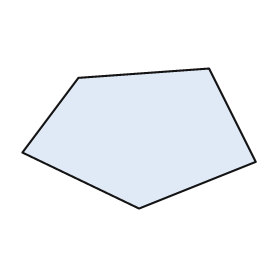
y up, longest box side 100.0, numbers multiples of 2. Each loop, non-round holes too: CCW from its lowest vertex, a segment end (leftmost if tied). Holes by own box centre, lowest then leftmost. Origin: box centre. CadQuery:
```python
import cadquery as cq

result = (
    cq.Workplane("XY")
    .moveTo(0.0, -30.0)
    .lineTo(50.0, -10.0)
    .lineTo(30.0, 30.0)
    .lineTo(-26.0, 26.0)
    .lineTo(-50.0, -6.0)
    .close()
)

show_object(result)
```